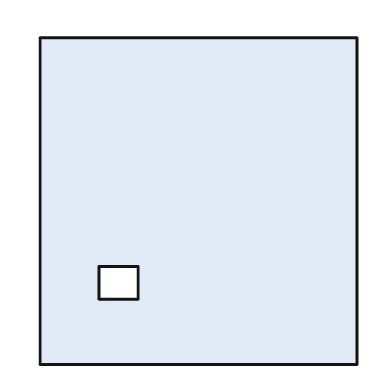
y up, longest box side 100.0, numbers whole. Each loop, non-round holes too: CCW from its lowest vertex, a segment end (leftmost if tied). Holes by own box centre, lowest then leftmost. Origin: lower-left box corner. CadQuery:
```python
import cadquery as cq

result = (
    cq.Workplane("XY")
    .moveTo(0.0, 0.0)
    .lineTo(97.0, 0.0)
    .lineTo(97.0, 100.0)
    .lineTo(0.0, 100.0)
    .close()
    .moveTo(18.0, 20.0)
    .lineTo(30.0, 20.0)
    .lineTo(30.0, 30.0)
    .lineTo(18.0, 30.0)
    .close()
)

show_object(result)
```